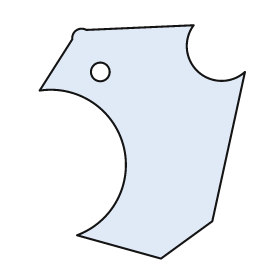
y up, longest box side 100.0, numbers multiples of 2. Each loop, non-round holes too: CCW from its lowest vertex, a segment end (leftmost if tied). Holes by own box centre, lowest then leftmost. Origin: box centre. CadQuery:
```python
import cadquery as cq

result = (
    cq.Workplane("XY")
    .moveTo(8.0, -50.0)
    .lineTo(30.0, -34.0)
    .lineTo(44.0, 30.0)
    .threePointArc((24.0, 30.0), (22.0, 50.0))
    .lineTo(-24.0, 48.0)
    .threePointArc((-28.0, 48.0), (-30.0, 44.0))
    .lineTo(-44.0, 22.0)
    .threePointArc((-8.0, -2.0), (-28.0, -40.0))
    .close()
    .moveTo(-18.0, 30.0)
    .circle(4.0)
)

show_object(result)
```